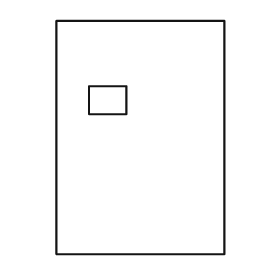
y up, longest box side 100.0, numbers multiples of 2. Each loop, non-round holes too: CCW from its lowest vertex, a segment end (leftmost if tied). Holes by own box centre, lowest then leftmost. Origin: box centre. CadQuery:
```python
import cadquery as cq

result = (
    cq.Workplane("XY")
    .moveTo(-36.0, -50.0)
    .lineTo(36.0, -50.0)
    .lineTo(36.0, 50.0)
    .lineTo(-36.0, 50.0)
    .close()
    .moveTo(-22.0, 10.0)
    .lineTo(-6.0, 10.0)
    .lineTo(-6.0, 22.0)
    .lineTo(-22.0, 22.0)
    .close()
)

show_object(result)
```